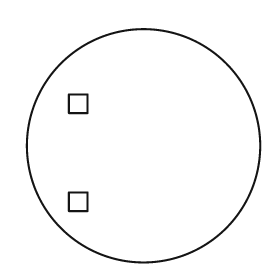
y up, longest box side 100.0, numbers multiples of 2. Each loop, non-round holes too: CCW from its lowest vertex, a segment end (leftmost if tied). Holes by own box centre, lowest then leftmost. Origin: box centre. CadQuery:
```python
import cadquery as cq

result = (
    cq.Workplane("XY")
    .moveTo(0.0, 0.0)
    .circle(50.0)
    .moveTo(-32.0, -28.0)
    .lineTo(-24.0, -28.0)
    .lineTo(-24.0, -20.0)
    .lineTo(-32.0, -20.0)
    .close()
    .moveTo(-32.0, 14.0)
    .lineTo(-24.0, 14.0)
    .lineTo(-24.0, 22.0)
    .lineTo(-32.0, 22.0)
    .close()
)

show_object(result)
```